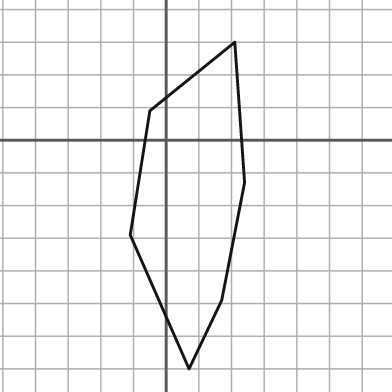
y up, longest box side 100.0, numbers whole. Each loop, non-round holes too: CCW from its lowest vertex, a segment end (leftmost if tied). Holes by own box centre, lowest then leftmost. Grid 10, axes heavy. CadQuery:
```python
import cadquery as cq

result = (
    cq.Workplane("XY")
    .moveTo(7.0, -70.0)
    .lineTo(17.0, -49.0)
    .lineTo(24.0, -13.0)
    .lineTo(21.0, 30.0)
    .lineTo(-5.0, 9.0)
    .lineTo(-11.0, -29.0)
    .close()
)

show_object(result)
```